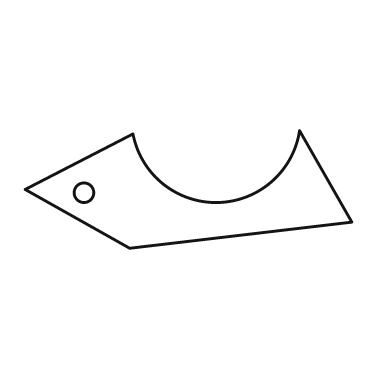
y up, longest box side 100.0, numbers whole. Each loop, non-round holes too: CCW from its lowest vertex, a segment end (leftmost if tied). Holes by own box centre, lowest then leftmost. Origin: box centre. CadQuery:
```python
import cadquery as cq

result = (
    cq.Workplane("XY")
    .moveTo(-18.0, -18.0)
    .lineTo(50.0, -10.0)
    .lineTo(34.0, 18.0)
    .threePointArc((9.0, -4.0), (-17.0, 17.0))
    .lineTo(-50.0, 0.0)
    .close()
    .moveTo(-32.0, -1.0)
    .circle(3.0)
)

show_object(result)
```